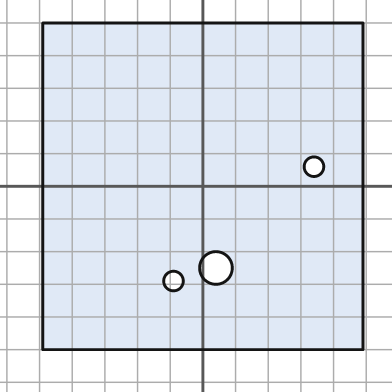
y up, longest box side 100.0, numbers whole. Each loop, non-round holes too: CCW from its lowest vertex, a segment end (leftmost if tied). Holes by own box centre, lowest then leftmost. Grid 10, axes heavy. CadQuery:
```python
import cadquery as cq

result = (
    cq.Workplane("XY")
    .moveTo(-49.0, -50.0)
    .lineTo(49.0, -50.0)
    .lineTo(49.0, 50.0)
    .lineTo(-49.0, 50.0)
    .close()
    .moveTo(-9.0, -29.0)
    .circle(3.0)
    .moveTo(4.0, -25.0)
    .circle(5.0)
    .moveTo(34.0, 6.0)
    .circle(3.0)
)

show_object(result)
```